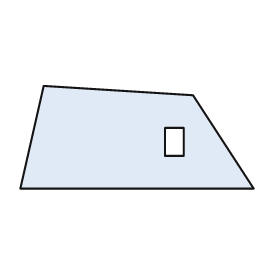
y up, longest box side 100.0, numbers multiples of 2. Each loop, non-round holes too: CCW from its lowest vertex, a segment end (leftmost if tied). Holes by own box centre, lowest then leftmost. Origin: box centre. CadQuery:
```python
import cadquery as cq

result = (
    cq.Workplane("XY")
    .moveTo(-50.0, -22.0)
    .lineTo(50.0, -22.0)
    .lineTo(24.0, 18.0)
    .lineTo(-40.0, 22.0)
    .close()
    .moveTo(12.0, -8.0)
    .lineTo(20.0, -8.0)
    .lineTo(20.0, 4.0)
    .lineTo(12.0, 4.0)
    .close()
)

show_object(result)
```